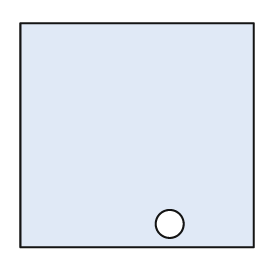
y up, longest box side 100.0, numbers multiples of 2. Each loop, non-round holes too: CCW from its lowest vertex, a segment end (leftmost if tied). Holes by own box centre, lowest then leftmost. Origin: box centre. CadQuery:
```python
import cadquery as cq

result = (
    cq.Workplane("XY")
    .moveTo(-50.0, -48.0)
    .lineTo(50.0, -48.0)
    .lineTo(50.0, 48.0)
    .lineTo(-50.0, 48.0)
    .close()
    .moveTo(14.0, -38.0)
    .circle(6.0)
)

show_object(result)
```